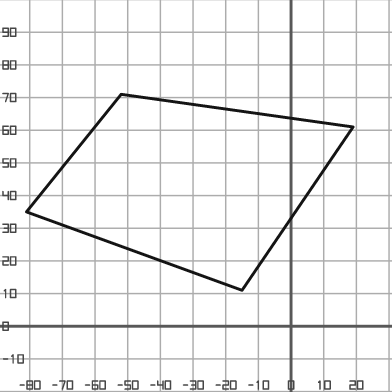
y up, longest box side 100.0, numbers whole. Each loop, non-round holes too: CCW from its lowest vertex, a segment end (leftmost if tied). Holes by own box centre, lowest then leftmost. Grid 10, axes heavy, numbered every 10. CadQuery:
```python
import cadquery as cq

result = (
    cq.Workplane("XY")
    .moveTo(-15.0, 11.0)
    .lineTo(19.0, 61.0)
    .lineTo(-52.0, 71.0)
    .lineTo(-81.0, 35.0)
    .close()
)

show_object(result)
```